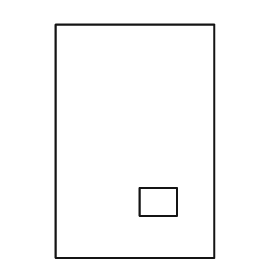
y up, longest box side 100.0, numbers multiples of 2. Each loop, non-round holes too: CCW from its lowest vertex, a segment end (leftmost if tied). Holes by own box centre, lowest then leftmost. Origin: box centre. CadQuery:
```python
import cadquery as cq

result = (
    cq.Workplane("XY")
    .moveTo(-34.0, -50.0)
    .lineTo(34.0, -50.0)
    .lineTo(34.0, 50.0)
    .lineTo(-34.0, 50.0)
    .close()
    .moveTo(2.0, -32.0)
    .lineTo(18.0, -32.0)
    .lineTo(18.0, -20.0)
    .lineTo(2.0, -20.0)
    .close()
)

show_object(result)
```